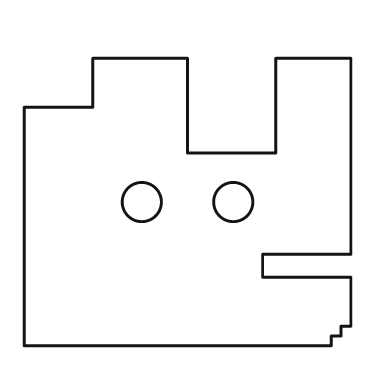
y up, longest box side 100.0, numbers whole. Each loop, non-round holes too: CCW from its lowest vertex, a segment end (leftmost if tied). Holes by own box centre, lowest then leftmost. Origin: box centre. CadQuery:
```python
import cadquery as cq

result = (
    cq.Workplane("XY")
    .moveTo(-50.0, -44.0)
    .lineTo(44.0, -44.0)
    .lineTo(44.0, -41.0)
    .lineTo(47.0, -41.0)
    .lineTo(47.0, -38.0)
    .lineTo(50.0, -38.0)
    .lineTo(50.0, -23.0)
    .lineTo(23.0, -23.0)
    .lineTo(23.0, -16.0)
    .lineTo(50.0, -16.0)
    .lineTo(50.0, 44.0)
    .lineTo(27.0, 44.0)
    .lineTo(27.0, 15.0)
    .lineTo(0.0, 15.0)
    .lineTo(0.0, 44.0)
    .lineTo(-29.0, 44.0)
    .lineTo(-29.0, 29.0)
    .lineTo(-50.0, 29.0)
    .close()
    .moveTo(-14.0, 0.0)
    .circle(6.0)
    .moveTo(14.0, 0.0)
    .circle(6.0)
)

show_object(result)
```